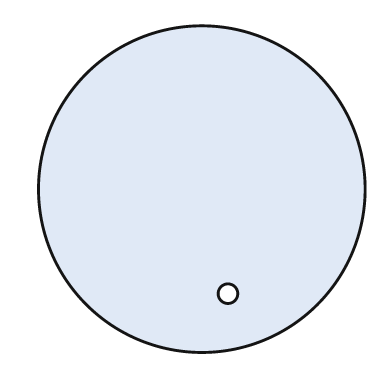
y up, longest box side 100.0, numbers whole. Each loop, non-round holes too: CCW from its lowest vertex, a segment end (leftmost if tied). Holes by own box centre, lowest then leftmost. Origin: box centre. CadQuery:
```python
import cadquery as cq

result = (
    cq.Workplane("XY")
    .moveTo(0.0, 0.0)
    .circle(50.0)
    .moveTo(8.0, -32.0)
    .circle(3.0)
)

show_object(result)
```